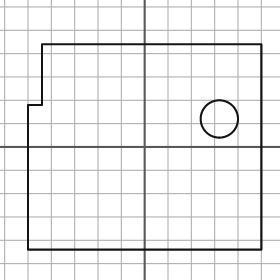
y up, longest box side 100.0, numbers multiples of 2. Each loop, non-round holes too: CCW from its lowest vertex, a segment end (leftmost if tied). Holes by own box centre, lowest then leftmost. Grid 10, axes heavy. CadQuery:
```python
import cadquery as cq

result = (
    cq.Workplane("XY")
    .moveTo(-50.0, -44.0)
    .lineTo(50.0, -44.0)
    .lineTo(50.0, 44.0)
    .lineTo(-44.0, 44.0)
    .lineTo(-44.0, 18.0)
    .lineTo(-50.0, 18.0)
    .close()
    .moveTo(32.0, 12.0)
    .circle(8.0)
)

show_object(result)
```